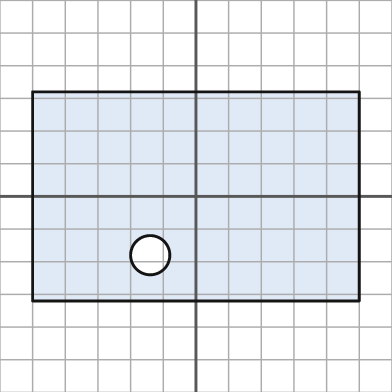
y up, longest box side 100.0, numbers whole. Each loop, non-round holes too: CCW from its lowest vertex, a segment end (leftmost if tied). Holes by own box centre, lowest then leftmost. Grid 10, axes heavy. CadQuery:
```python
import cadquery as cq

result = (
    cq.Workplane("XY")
    .moveTo(-50.0, -32.0)
    .lineTo(50.0, -32.0)
    .lineTo(50.0, 32.0)
    .lineTo(-50.0, 32.0)
    .close()
    .moveTo(-14.0, -18.0)
    .circle(6.0)
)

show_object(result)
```